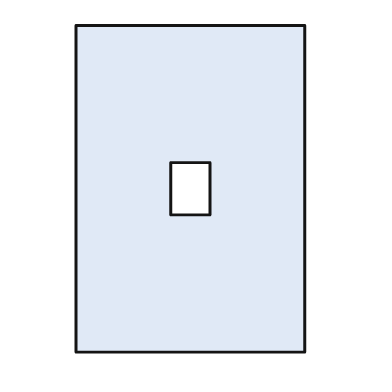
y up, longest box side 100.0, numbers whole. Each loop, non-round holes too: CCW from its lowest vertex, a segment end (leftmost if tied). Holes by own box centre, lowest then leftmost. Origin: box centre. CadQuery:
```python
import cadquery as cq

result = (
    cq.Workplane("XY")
    .moveTo(-35.0, -50.0)
    .lineTo(35.0, -50.0)
    .lineTo(35.0, 50.0)
    .lineTo(-35.0, 50.0)
    .close()
    .moveTo(-6.0, -8.0)
    .lineTo(6.0, -8.0)
    .lineTo(6.0, 8.0)
    .lineTo(-6.0, 8.0)
    .close()
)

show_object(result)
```